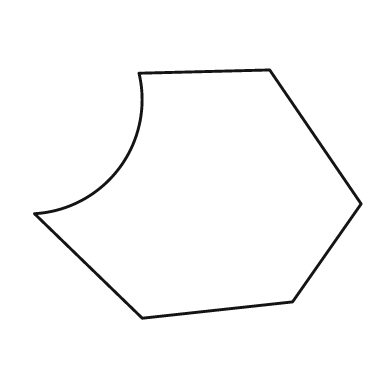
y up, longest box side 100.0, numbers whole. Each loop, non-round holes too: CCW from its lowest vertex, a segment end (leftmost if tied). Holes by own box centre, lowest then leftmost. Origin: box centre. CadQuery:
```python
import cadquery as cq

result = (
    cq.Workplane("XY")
    .moveTo(-17.0, -38.0)
    .lineTo(29.0, -33.0)
    .lineTo(50.0, -3.0)
    .lineTo(22.0, 38.0)
    .lineTo(-18.0, 37.0)
    .threePointArc((-24.0, 8.0), (-50.0, -6.0))
    .close()
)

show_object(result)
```